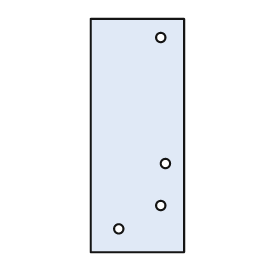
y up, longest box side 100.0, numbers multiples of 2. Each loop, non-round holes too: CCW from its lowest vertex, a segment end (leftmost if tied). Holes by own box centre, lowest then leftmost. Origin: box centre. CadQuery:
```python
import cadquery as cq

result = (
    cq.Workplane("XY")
    .moveTo(-20.0, -50.0)
    .lineTo(20.0, -50.0)
    .lineTo(20.0, 50.0)
    .lineTo(-20.0, 50.0)
    .close()
    .moveTo(-8.0, -40.0)
    .circle(2.0)
    .moveTo(10.0, -30.0)
    .circle(2.0)
    .moveTo(12.0, -12.0)
    .circle(2.0)
    .moveTo(10.0, 42.0)
    .circle(2.0)
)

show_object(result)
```